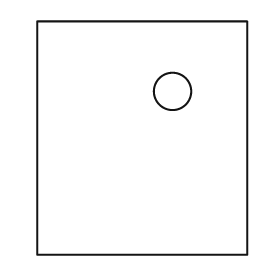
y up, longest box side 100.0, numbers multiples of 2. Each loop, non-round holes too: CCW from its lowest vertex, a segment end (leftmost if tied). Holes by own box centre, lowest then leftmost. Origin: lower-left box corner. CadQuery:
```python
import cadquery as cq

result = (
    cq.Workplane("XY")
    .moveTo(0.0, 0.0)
    .lineTo(90.0, 0.0)
    .lineTo(90.0, 100.0)
    .lineTo(0.0, 100.0)
    .close()
    .moveTo(58.0, 70.0)
    .circle(8.0)
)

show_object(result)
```